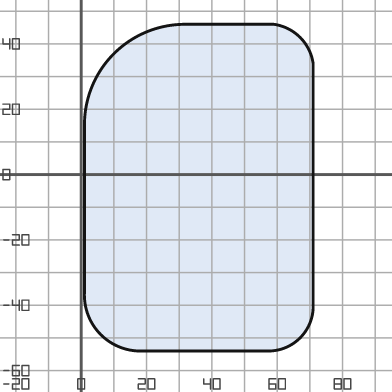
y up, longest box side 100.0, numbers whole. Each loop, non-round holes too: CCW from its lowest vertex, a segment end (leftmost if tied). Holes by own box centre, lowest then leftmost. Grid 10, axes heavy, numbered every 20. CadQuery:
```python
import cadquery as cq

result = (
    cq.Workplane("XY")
    .moveTo(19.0, -54.0)
    .lineTo(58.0, -54.0)
    .threePointArc((67.0, -50.0), (71.0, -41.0))
    .lineTo(71.0, 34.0)
    .threePointArc((67.0, 42.0), (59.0, 46.0))
    .lineTo(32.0, 46.0)
    .threePointArc((10.0, 37.0), (1.0, 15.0))
    .lineTo(1.0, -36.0)
    .threePointArc((6.0, -49.0), (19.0, -54.0))
    .close()
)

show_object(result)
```